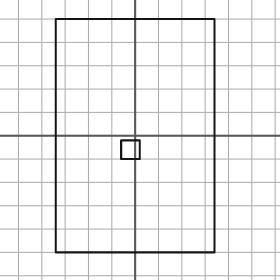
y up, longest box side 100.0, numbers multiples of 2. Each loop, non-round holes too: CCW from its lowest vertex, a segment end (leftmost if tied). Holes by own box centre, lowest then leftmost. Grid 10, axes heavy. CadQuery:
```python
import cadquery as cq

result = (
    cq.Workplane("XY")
    .moveTo(-34.0, -50.0)
    .lineTo(34.0, -50.0)
    .lineTo(34.0, 50.0)
    .lineTo(-34.0, 50.0)
    .close()
    .moveTo(-6.0, -10.0)
    .lineTo(2.0, -10.0)
    .lineTo(2.0, -2.0)
    .lineTo(-6.0, -2.0)
    .close()
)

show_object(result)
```